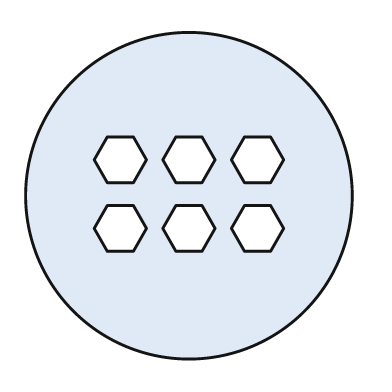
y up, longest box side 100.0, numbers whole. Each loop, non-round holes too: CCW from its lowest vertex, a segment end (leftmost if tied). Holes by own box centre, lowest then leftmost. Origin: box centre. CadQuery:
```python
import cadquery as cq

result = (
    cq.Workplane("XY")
    .moveTo(0.0, 0.0)
    .circle(50.0)
    .moveTo(-25.0, -17.0)
    .lineTo(-17.0, -17.0)
    .lineTo(-13.0, -10.0)
    .lineTo(-17.0, -3.0)
    .lineTo(-25.0, -3.0)
    .lineTo(-29.0, -10.0)
    .close()
    .moveTo(-4.0, -17.0)
    .lineTo(4.0, -17.0)
    .lineTo(8.0, -10.0)
    .lineTo(4.0, -3.0)
    .lineTo(-4.0, -3.0)
    .lineTo(-8.0, -10.0)
    .close()
    .moveTo(17.0, -17.0)
    .lineTo(25.0, -17.0)
    .lineTo(29.0, -10.0)
    .lineTo(25.0, -3.0)
    .lineTo(17.0, -3.0)
    .lineTo(13.0, -10.0)
    .close()
    .moveTo(-25.0, 4.0)
    .lineTo(-17.0, 4.0)
    .lineTo(-13.0, 11.0)
    .lineTo(-17.0, 18.0)
    .lineTo(-25.0, 18.0)
    .lineTo(-29.0, 11.0)
    .close()
    .moveTo(-4.0, 4.0)
    .lineTo(4.0, 4.0)
    .lineTo(8.0, 11.0)
    .lineTo(4.0, 18.0)
    .lineTo(-4.0, 18.0)
    .lineTo(-8.0, 11.0)
    .close()
    .moveTo(17.0, 4.0)
    .lineTo(25.0, 4.0)
    .lineTo(29.0, 11.0)
    .lineTo(25.0, 18.0)
    .lineTo(17.0, 18.0)
    .lineTo(13.0, 11.0)
    .close()
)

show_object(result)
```